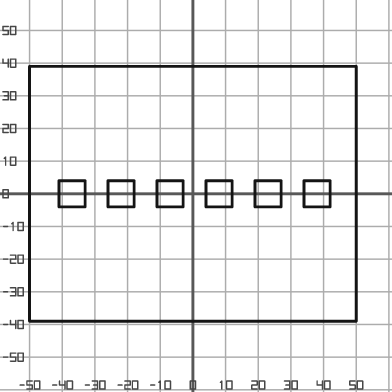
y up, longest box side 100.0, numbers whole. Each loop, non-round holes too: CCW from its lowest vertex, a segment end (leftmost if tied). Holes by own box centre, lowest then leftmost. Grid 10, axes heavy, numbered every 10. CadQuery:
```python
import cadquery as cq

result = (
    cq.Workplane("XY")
    .moveTo(-50.0, -39.0)
    .lineTo(50.0, -39.0)
    .lineTo(50.0, 39.0)
    .lineTo(-50.0, 39.0)
    .close()
    .moveTo(-41.0, -4.0)
    .lineTo(-33.0, -4.0)
    .lineTo(-33.0, 4.0)
    .lineTo(-41.0, 4.0)
    .close()
    .moveTo(-26.0, -4.0)
    .lineTo(-18.0, -4.0)
    .lineTo(-18.0, 4.0)
    .lineTo(-26.0, 4.0)
    .close()
    .moveTo(-11.0, -4.0)
    .lineTo(-3.0, -4.0)
    .lineTo(-3.0, 4.0)
    .lineTo(-11.0, 4.0)
    .close()
    .moveTo(4.0, -4.0)
    .lineTo(12.0, -4.0)
    .lineTo(12.0, 4.0)
    .lineTo(4.0, 4.0)
    .close()
    .moveTo(19.0, -4.0)
    .lineTo(27.0, -4.0)
    .lineTo(27.0, 4.0)
    .lineTo(19.0, 4.0)
    .close()
    .moveTo(34.0, -4.0)
    .lineTo(42.0, -4.0)
    .lineTo(42.0, 4.0)
    .lineTo(34.0, 4.0)
    .close()
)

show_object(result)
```